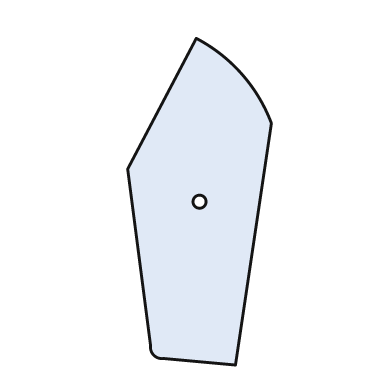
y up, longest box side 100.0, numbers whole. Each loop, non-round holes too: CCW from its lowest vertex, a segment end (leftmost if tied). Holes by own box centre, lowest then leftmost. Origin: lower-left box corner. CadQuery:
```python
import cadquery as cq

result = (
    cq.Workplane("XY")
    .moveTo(33.0, 0.0)
    .lineTo(44.0, 74.0)
    .threePointArc((35.0, 89.0), (21.0, 100.0))
    .lineTo(0.0, 60.0)
    .lineTo(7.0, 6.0)
    .threePointArc((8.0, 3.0), (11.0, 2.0))
    .close()
    .moveTo(22.0, 50.0)
    .circle(2.0)
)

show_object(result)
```